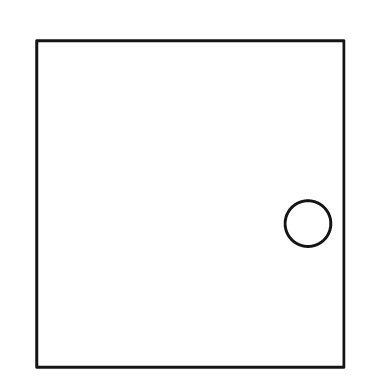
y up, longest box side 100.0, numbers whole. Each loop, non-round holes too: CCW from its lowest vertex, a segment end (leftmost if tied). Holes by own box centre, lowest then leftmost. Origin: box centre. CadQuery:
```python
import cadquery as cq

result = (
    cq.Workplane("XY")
    .moveTo(-47.0, -50.0)
    .lineTo(47.0, -50.0)
    .lineTo(47.0, 50.0)
    .lineTo(-47.0, 50.0)
    .close()
    .moveTo(36.0, -6.0)
    .circle(7.0)
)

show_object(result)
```